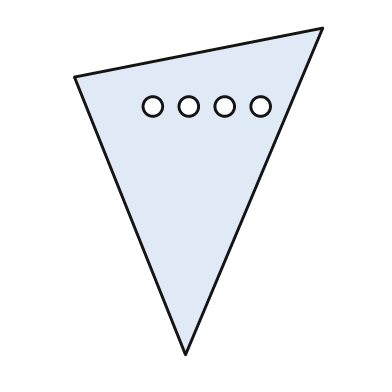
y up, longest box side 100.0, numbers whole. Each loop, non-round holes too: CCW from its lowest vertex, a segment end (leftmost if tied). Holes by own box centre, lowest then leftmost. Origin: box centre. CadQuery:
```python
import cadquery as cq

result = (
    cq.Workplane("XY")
    .moveTo(-4.0, -50.0)
    .lineTo(38.0, 50.0)
    .lineTo(-38.0, 35.0)
    .close()
    .moveTo(-14.0, 26.0)
    .circle(3.0)
    .moveTo(-3.0, 26.0)
    .circle(3.0)
    .moveTo(8.0, 26.0)
    .circle(3.0)
    .moveTo(19.0, 26.0)
    .circle(3.0)
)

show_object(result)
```